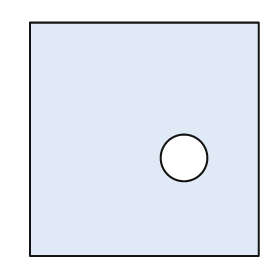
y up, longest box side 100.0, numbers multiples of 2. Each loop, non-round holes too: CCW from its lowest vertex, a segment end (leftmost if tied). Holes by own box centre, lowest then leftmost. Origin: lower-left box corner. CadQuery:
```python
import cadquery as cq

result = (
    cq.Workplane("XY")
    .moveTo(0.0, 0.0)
    .lineTo(98.0, 0.0)
    .lineTo(98.0, 100.0)
    .lineTo(0.0, 100.0)
    .close()
    .moveTo(66.0, 42.0)
    .circle(10.0)
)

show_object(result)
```